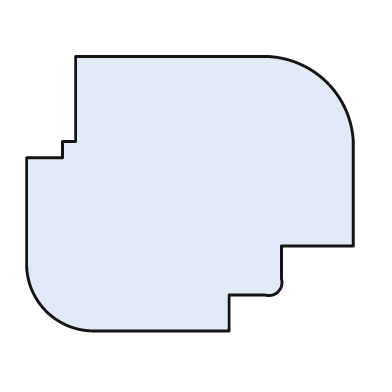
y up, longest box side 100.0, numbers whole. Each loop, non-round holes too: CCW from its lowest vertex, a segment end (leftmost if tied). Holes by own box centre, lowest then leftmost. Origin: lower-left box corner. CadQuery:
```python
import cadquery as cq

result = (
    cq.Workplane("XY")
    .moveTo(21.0, 0.0)
    .lineTo(62.0, 0.0)
    .lineTo(62.0, 11.0)
    .lineTo(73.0, 11.0)
    .threePointArc((77.0, 12.0), (78.0, 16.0))
    .lineTo(78.0, 26.0)
    .lineTo(100.0, 26.0)
    .lineTo(100.0, 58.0)
    .threePointArc((92.0, 76.0), (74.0, 84.0))
    .lineTo(15.0, 84.0)
    .lineTo(15.0, 58.0)
    .lineTo(11.0, 58.0)
    .lineTo(11.0, 53.0)
    .lineTo(0.0, 53.0)
    .lineTo(0.0, 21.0)
    .threePointArc((6.0, 6.0), (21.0, 0.0))
    .close()
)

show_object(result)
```